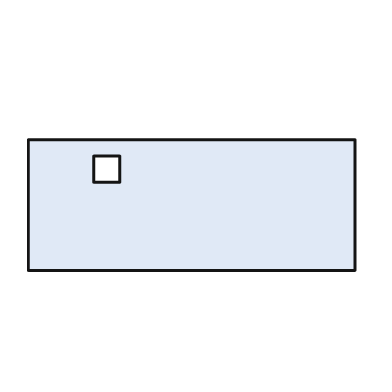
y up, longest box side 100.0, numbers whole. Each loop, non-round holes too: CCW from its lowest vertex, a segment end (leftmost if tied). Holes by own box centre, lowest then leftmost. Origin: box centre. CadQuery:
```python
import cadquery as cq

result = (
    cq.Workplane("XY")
    .moveTo(-50.0, -20.0)
    .lineTo(50.0, -20.0)
    .lineTo(50.0, 20.0)
    .lineTo(-50.0, 20.0)
    .close()
    .moveTo(-30.0, 7.0)
    .lineTo(-22.0, 7.0)
    .lineTo(-22.0, 15.0)
    .lineTo(-30.0, 15.0)
    .close()
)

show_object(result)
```